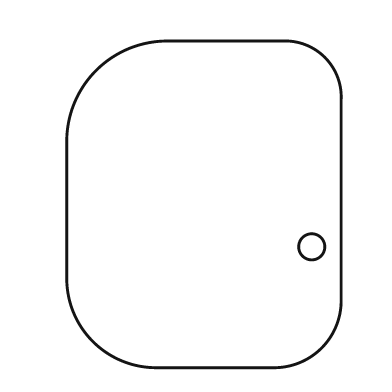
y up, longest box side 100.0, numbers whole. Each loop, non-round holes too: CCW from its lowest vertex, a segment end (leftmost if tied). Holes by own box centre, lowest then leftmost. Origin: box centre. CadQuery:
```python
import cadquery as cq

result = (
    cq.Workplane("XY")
    .moveTo(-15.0, -50.0)
    .lineTo(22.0, -50.0)
    .threePointArc((36.0, -44.0), (42.0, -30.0))
    .lineTo(42.0, 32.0)
    .threePointArc((37.0, 45.0), (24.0, 50.0))
    .lineTo(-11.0, 50.0)
    .threePointArc((-33.0, 41.0), (-42.0, 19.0))
    .lineTo(-42.0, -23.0)
    .threePointArc((-34.0, -42.0), (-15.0, -50.0))
    .close()
    .moveTo(33.0, -13.0)
    .circle(4.0)
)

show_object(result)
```